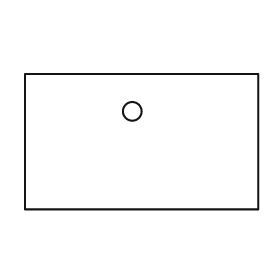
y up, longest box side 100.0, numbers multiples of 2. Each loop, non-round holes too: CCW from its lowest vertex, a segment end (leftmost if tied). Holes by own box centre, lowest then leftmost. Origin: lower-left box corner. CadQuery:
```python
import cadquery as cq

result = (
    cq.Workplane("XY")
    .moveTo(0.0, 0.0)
    .lineTo(100.0, 0.0)
    .lineTo(100.0, 58.0)
    .lineTo(0.0, 58.0)
    .close()
    .moveTo(46.0, 42.0)
    .circle(4.0)
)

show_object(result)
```